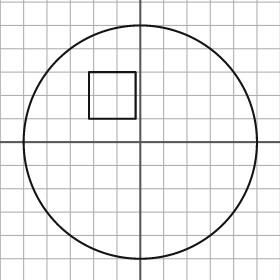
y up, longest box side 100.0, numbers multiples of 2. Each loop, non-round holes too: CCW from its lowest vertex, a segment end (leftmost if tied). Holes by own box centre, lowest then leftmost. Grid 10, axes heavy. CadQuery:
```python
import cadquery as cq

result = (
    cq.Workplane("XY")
    .moveTo(0.0, 0.0)
    .circle(50.0)
    .moveTo(-22.0, 10.0)
    .lineTo(-2.0, 10.0)
    .lineTo(-2.0, 30.0)
    .lineTo(-22.0, 30.0)
    .close()
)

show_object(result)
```